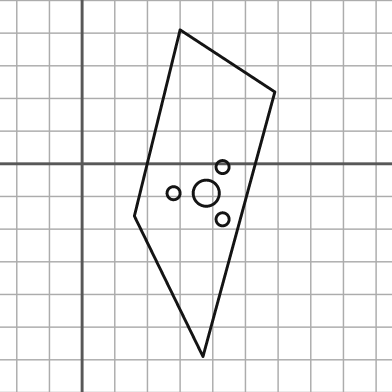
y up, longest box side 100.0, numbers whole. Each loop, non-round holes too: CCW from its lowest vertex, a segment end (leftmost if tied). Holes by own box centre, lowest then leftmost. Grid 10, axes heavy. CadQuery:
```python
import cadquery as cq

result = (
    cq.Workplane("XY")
    .moveTo(37.0, -59.0)
    .lineTo(59.0, 22.0)
    .lineTo(30.0, 41.0)
    .lineTo(16.0, -16.0)
    .close()
    .moveTo(43.0, -17.0)
    .circle(2.0)
    .moveTo(28.0, -9.0)
    .circle(2.0)
    .moveTo(38.0, -9.0)
    .circle(4.0)
    .moveTo(43.0, -1.0)
    .circle(2.0)
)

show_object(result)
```